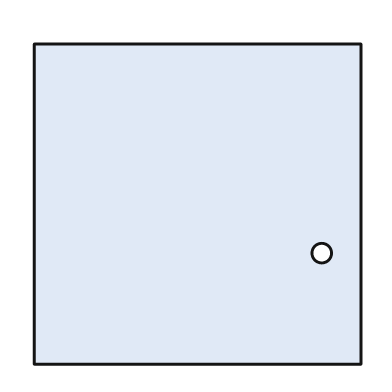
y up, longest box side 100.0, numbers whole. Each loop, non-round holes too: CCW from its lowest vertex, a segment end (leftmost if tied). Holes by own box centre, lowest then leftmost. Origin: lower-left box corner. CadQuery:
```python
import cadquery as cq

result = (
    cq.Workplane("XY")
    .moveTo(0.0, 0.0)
    .lineTo(100.0, 0.0)
    .lineTo(100.0, 98.0)
    .lineTo(0.0, 98.0)
    .close()
    .moveTo(88.0, 34.0)
    .circle(3.0)
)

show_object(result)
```